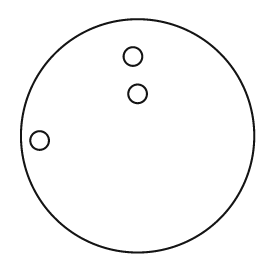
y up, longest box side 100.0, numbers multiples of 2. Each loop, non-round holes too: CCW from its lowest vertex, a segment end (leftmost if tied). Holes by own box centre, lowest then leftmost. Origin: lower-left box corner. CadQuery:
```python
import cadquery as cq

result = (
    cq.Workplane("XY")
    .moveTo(50.0, 50.0)
    .circle(50.0)
    .moveTo(8.0, 48.0)
    .circle(4.0)
    .moveTo(50.0, 68.0)
    .circle(4.0)
    .moveTo(48.0, 84.0)
    .circle(4.0)
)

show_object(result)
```